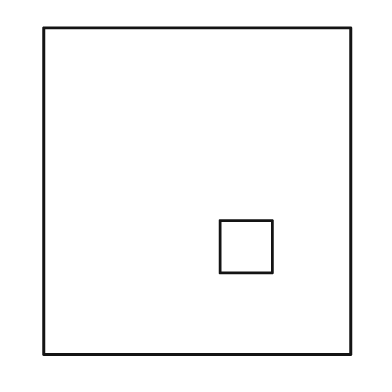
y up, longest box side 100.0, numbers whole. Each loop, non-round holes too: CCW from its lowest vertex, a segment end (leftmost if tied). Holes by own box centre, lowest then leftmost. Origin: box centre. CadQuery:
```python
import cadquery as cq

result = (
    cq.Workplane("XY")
    .moveTo(-47.0, -50.0)
    .lineTo(47.0, -50.0)
    .lineTo(47.0, 50.0)
    .lineTo(-47.0, 50.0)
    .close()
    .moveTo(7.0, -25.0)
    .lineTo(23.0, -25.0)
    .lineTo(23.0, -9.0)
    .lineTo(7.0, -9.0)
    .close()
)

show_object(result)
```